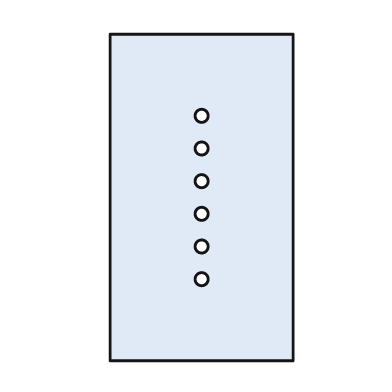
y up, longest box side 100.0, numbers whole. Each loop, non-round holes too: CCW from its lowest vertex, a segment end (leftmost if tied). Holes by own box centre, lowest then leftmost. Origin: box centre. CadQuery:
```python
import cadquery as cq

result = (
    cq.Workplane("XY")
    .moveTo(-28.0, -50.0)
    .lineTo(28.0, -50.0)
    .lineTo(28.0, 50.0)
    .lineTo(-28.0, 50.0)
    .close()
    .moveTo(0.0, -25.0)
    .circle(2.0)
    .moveTo(0.0, -15.0)
    .circle(2.0)
    .moveTo(0.0, -5.0)
    .circle(2.0)
    .moveTo(0.0, 5.0)
    .circle(2.0)
    .moveTo(0.0, 15.0)
    .circle(2.0)
    .moveTo(0.0, 25.0)
    .circle(2.0)
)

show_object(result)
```